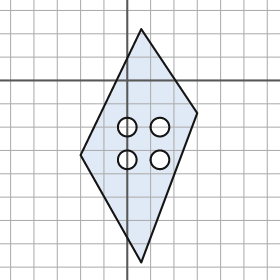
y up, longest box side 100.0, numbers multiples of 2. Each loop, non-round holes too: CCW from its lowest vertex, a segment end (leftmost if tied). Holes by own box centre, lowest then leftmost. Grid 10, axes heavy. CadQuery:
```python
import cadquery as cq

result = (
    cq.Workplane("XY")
    .moveTo(6.0, -78.0)
    .lineTo(30.0, -14.0)
    .lineTo(6.0, 22.0)
    .lineTo(-20.0, -32.0)
    .close()
    .moveTo(0.0, -34.0)
    .circle(4.0)
    .moveTo(14.0, -34.0)
    .circle(4.0)
    .moveTo(0.0, -20.0)
    .circle(4.0)
    .moveTo(14.0, -20.0)
    .circle(4.0)
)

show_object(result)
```